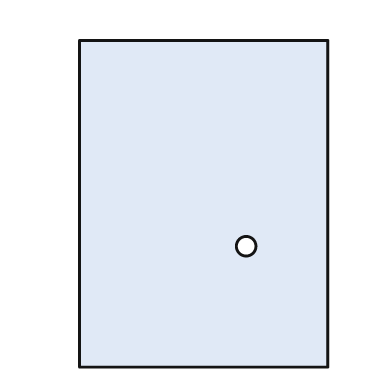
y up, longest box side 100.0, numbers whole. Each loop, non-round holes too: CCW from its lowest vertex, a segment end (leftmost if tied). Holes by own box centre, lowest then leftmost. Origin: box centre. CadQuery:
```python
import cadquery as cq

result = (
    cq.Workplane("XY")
    .moveTo(-38.0, -50.0)
    .lineTo(38.0, -50.0)
    .lineTo(38.0, 50.0)
    .lineTo(-38.0, 50.0)
    .close()
    .moveTo(13.0, -13.0)
    .circle(3.0)
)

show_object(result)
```